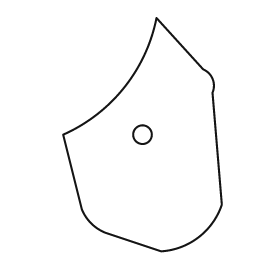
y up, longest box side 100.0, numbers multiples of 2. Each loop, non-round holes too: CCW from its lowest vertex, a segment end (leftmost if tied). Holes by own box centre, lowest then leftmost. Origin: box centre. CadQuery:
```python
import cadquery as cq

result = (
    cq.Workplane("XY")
    .moveTo(8.0, -50.0)
    .threePointArc((24.0, -44.0), (34.0, -30.0))
    .lineTo(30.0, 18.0)
    .threePointArc((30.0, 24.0), (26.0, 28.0))
    .lineTo(6.0, 50.0)
    .threePointArc((-8.0, 20.0), (-34.0, 0.0))
    .lineTo(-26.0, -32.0)
    .threePointArc((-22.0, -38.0), (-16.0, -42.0))
    .close()
    .moveTo(0.0, 0.0)
    .circle(4.0)
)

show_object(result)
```